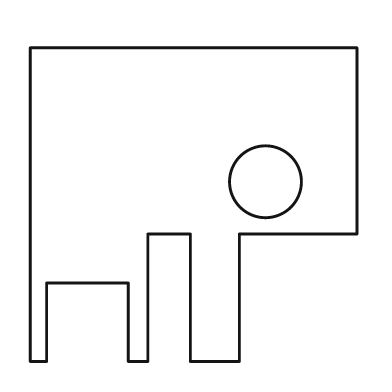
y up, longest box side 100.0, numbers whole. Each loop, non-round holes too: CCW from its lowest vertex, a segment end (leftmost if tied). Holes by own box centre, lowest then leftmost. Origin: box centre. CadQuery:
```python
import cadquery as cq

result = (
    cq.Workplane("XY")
    .moveTo(-50.0, -48.0)
    .lineTo(-45.0, -48.0)
    .lineTo(-45.0, -24.0)
    .lineTo(-20.0, -24.0)
    .lineTo(-20.0, -48.0)
    .lineTo(-14.0, -48.0)
    .lineTo(-14.0, -9.0)
    .lineTo(-1.0, -9.0)
    .lineTo(-1.0, -48.0)
    .lineTo(14.0, -48.0)
    .lineTo(14.0, -9.0)
    .lineTo(50.0, -9.0)
    .lineTo(50.0, 48.0)
    .lineTo(-50.0, 48.0)
    .close()
    .moveTo(22.0, 7.0)
    .circle(11.0)
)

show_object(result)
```